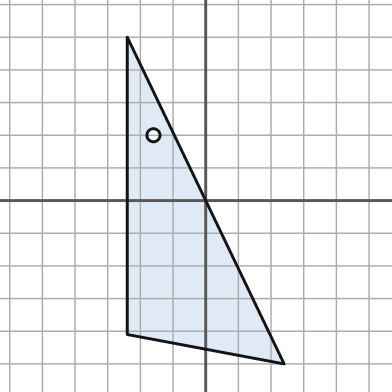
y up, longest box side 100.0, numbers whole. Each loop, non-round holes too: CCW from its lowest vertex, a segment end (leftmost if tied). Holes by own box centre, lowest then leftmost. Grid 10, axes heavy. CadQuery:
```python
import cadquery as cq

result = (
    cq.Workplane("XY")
    .moveTo(24.0, -50.0)
    .lineTo(-24.0, 50.0)
    .lineTo(-24.0, -41.0)
    .close()
    .moveTo(-16.0, 20.0)
    .circle(2.0)
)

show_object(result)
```